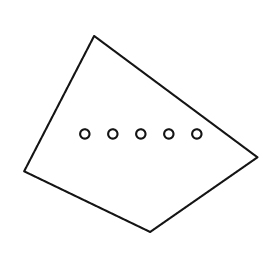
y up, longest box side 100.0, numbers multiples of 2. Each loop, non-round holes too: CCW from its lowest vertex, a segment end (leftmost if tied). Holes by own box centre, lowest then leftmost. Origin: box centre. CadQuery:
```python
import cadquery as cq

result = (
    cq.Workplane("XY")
    .moveTo(4.0, -42.0)
    .lineTo(50.0, -10.0)
    .lineTo(-20.0, 42.0)
    .lineTo(-50.0, -16.0)
    .close()
    .moveTo(-24.0, 0.0)
    .circle(2.0)
    .moveTo(-12.0, 0.0)
    .circle(2.0)
    .moveTo(0.0, 0.0)
    .circle(2.0)
    .moveTo(12.0, 0.0)
    .circle(2.0)
    .moveTo(24.0, 0.0)
    .circle(2.0)
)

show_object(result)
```